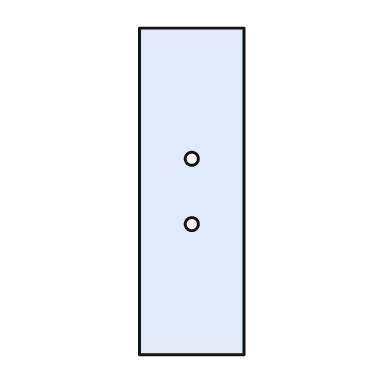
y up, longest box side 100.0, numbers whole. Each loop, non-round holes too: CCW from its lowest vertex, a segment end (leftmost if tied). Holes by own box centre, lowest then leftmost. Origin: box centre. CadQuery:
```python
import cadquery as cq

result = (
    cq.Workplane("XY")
    .moveTo(-16.0, -50.0)
    .lineTo(16.0, -50.0)
    .lineTo(16.0, 50.0)
    .lineTo(-16.0, 50.0)
    .close()
    .moveTo(0.0, -10.0)
    .circle(2.0)
    .moveTo(0.0, 10.0)
    .circle(2.0)
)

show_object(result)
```